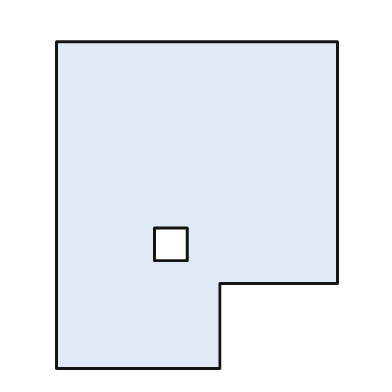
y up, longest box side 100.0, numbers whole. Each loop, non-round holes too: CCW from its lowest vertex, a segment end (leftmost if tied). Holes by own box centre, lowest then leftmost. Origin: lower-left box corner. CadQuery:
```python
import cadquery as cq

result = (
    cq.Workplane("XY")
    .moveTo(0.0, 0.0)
    .lineTo(50.0, 0.0)
    .lineTo(50.0, 26.0)
    .lineTo(86.0, 26.0)
    .lineTo(86.0, 100.0)
    .lineTo(0.0, 100.0)
    .close()
    .moveTo(30.0, 33.0)
    .lineTo(40.0, 33.0)
    .lineTo(40.0, 43.0)
    .lineTo(30.0, 43.0)
    .close()
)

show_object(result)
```